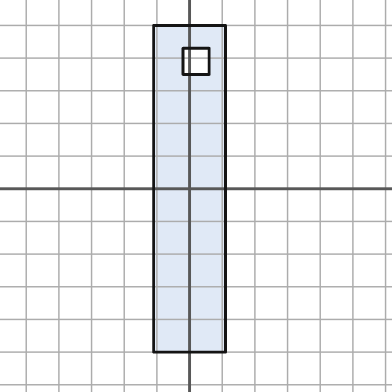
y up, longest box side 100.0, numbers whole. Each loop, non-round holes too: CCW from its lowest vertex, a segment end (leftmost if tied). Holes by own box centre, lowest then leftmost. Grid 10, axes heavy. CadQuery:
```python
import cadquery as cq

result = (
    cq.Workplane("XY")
    .moveTo(-11.0, -50.0)
    .lineTo(11.0, -50.0)
    .lineTo(11.0, 50.0)
    .lineTo(-11.0, 50.0)
    .close()
    .moveTo(-2.0, 35.0)
    .lineTo(6.0, 35.0)
    .lineTo(6.0, 43.0)
    .lineTo(-2.0, 43.0)
    .close()
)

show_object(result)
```